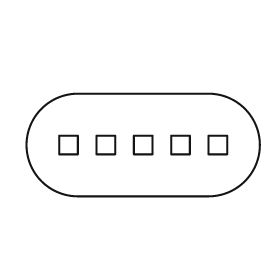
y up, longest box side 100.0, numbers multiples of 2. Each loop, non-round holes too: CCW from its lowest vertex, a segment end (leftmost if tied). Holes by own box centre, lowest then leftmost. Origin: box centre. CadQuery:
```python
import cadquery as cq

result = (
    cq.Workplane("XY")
    .moveTo(-28.0, -22.0)
    .lineTo(28.0, -22.0)
    .threePointArc((50.0, 0.0), (28.0, 22.0))
    .lineTo(-28.0, 22.0)
    .threePointArc((-50.0, 0.0), (-28.0, -22.0))
    .close()
    .moveTo(-36.0, -4.0)
    .lineTo(-28.0, -4.0)
    .lineTo(-28.0, 4.0)
    .lineTo(-36.0, 4.0)
    .close()
    .moveTo(-20.0, -4.0)
    .lineTo(-12.0, -4.0)
    .lineTo(-12.0, 4.0)
    .lineTo(-20.0, 4.0)
    .close()
    .moveTo(-4.0, -4.0)
    .lineTo(4.0, -4.0)
    .lineTo(4.0, 4.0)
    .lineTo(-4.0, 4.0)
    .close()
    .moveTo(12.0, -4.0)
    .lineTo(20.0, -4.0)
    .lineTo(20.0, 4.0)
    .lineTo(12.0, 4.0)
    .close()
    .moveTo(28.0, -4.0)
    .lineTo(36.0, -4.0)
    .lineTo(36.0, 4.0)
    .lineTo(28.0, 4.0)
    .close()
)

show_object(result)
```